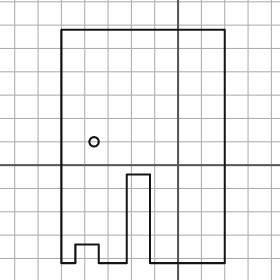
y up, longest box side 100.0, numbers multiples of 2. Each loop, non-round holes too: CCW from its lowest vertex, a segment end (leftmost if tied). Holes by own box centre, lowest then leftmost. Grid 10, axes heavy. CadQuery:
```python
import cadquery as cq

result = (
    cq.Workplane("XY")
    .moveTo(-50.0, -42.0)
    .lineTo(-44.0, -42.0)
    .lineTo(-44.0, -34.0)
    .lineTo(-34.0, -34.0)
    .lineTo(-34.0, -42.0)
    .lineTo(-22.0, -42.0)
    .lineTo(-22.0, -4.0)
    .lineTo(-12.0, -4.0)
    .lineTo(-12.0, -42.0)
    .lineTo(20.0, -42.0)
    .lineTo(20.0, 58.0)
    .lineTo(-50.0, 58.0)
    .close()
    .moveTo(-36.0, 10.0)
    .circle(2.0)
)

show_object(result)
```